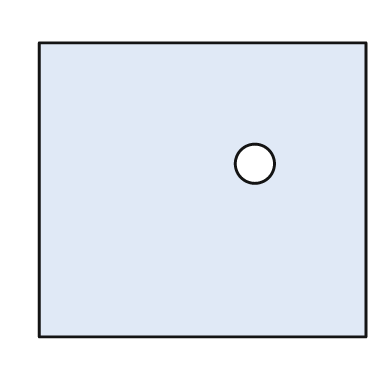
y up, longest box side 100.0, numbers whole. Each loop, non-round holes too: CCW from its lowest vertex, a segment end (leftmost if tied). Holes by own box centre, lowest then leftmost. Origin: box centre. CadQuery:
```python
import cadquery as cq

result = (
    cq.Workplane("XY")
    .moveTo(-50.0, -45.0)
    .lineTo(50.0, -45.0)
    .lineTo(50.0, 45.0)
    .lineTo(-50.0, 45.0)
    .close()
    .moveTo(16.0, 8.0)
    .circle(6.0)
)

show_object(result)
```